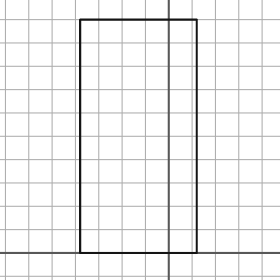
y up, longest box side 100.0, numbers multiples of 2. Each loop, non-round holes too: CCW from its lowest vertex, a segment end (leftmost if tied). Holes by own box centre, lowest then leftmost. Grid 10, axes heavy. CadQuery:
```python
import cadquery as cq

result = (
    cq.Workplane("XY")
    .moveTo(-38.0, 0.0)
    .lineTo(12.0, 0.0)
    .lineTo(12.0, 100.0)
    .lineTo(-38.0, 100.0)
    .close()
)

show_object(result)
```